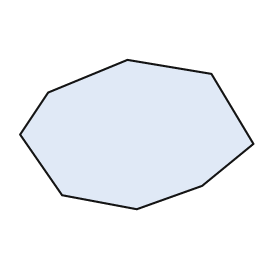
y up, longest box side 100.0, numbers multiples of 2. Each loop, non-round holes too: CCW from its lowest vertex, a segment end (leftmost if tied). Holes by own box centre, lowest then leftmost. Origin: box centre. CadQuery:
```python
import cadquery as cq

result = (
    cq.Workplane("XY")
    .moveTo(0.0, -32.0)
    .lineTo(28.0, -22.0)
    .lineTo(50.0, -4.0)
    .lineTo(32.0, 26.0)
    .lineTo(-4.0, 32.0)
    .lineTo(-38.0, 18.0)
    .lineTo(-50.0, 0.0)
    .lineTo(-32.0, -26.0)
    .close()
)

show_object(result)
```